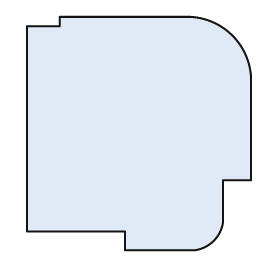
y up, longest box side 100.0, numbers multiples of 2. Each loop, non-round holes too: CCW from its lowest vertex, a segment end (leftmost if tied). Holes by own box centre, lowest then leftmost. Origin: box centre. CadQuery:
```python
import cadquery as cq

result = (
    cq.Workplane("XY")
    .moveTo(-6.0, -50.0)
    .lineTo(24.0, -50.0)
    .threePointArc((32.0, -46.0), (36.0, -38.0))
    .lineTo(36.0, -20.0)
    .lineTo(48.0, -20.0)
    .lineTo(48.0, 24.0)
    .threePointArc((40.0, 42.0), (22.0, 50.0))
    .lineTo(-34.0, 50.0)
    .lineTo(-34.0, 46.0)
    .lineTo(-48.0, 46.0)
    .lineTo(-48.0, -42.0)
    .lineTo(-6.0, -42.0)
    .close()
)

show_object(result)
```